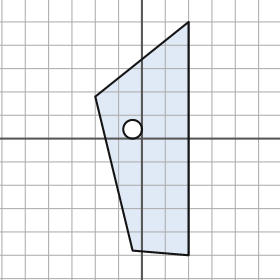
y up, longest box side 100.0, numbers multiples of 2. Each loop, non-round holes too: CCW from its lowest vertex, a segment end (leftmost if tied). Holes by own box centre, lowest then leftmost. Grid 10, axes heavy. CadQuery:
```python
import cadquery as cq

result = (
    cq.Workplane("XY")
    .moveTo(20.0, -50.0)
    .lineTo(20.0, 50.0)
    .lineTo(-20.0, 18.0)
    .lineTo(-4.0, -48.0)
    .close()
    .moveTo(-4.0, 4.0)
    .circle(4.0)
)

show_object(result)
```